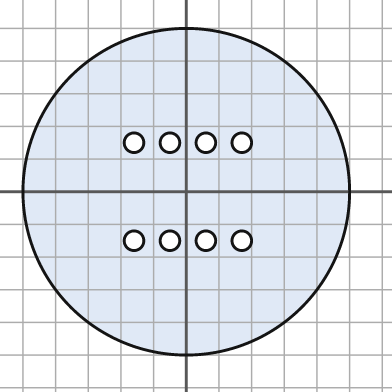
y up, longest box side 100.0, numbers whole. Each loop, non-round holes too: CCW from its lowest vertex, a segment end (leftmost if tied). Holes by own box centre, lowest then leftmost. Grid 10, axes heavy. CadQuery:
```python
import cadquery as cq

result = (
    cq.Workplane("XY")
    .moveTo(0.0, 0.0)
    .circle(50.0)
    .moveTo(-16.0, -15.0)
    .circle(3.0)
    .moveTo(-5.0, -15.0)
    .circle(3.0)
    .moveTo(6.0, -15.0)
    .circle(3.0)
    .moveTo(17.0, -15.0)
    .circle(3.0)
    .moveTo(-16.0, 15.0)
    .circle(3.0)
    .moveTo(-5.0, 15.0)
    .circle(3.0)
    .moveTo(6.0, 15.0)
    .circle(3.0)
    .moveTo(17.0, 15.0)
    .circle(3.0)
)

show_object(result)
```